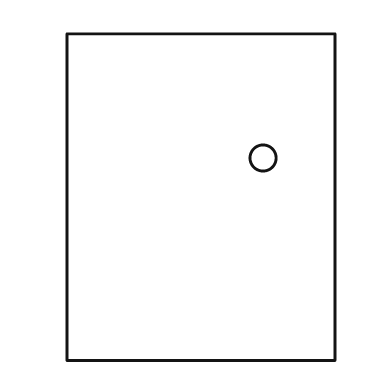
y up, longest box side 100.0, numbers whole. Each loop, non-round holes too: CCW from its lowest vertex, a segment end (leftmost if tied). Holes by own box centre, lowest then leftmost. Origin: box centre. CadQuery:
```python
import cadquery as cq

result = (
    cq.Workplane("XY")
    .moveTo(-41.0, -50.0)
    .lineTo(41.0, -50.0)
    .lineTo(41.0, 50.0)
    .lineTo(-41.0, 50.0)
    .close()
    .moveTo(19.0, 12.0)
    .circle(4.0)
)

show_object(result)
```